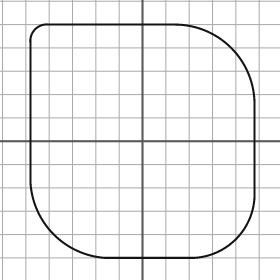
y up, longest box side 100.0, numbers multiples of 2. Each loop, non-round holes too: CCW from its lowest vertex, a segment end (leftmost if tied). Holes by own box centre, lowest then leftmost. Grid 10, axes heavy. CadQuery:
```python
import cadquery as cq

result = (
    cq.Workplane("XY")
    .moveTo(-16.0, -50.0)
    .lineTo(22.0, -50.0)
    .threePointArc((40.0, -42.0), (48.0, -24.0))
    .lineTo(48.0, 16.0)
    .threePointArc((38.0, 40.0), (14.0, 50.0))
    .lineTo(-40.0, 50.0)
    .threePointArc((-46.0, 48.0), (-48.0, 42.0))
    .lineTo(-48.0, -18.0)
    .threePointArc((-38.0, -40.0), (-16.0, -50.0))
    .close()
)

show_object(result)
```